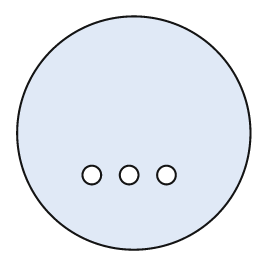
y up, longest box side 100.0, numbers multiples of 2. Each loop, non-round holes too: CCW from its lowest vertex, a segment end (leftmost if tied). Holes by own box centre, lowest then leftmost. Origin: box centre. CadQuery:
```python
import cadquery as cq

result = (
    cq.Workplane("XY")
    .moveTo(0.0, 0.0)
    .circle(50.0)
    .moveTo(-18.0, -18.0)
    .circle(4.0)
    .moveTo(-2.0, -18.0)
    .circle(4.0)
    .moveTo(14.0, -18.0)
    .circle(4.0)
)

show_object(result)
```